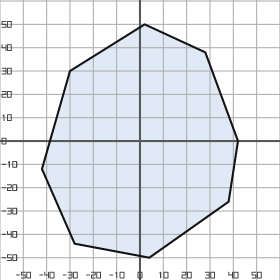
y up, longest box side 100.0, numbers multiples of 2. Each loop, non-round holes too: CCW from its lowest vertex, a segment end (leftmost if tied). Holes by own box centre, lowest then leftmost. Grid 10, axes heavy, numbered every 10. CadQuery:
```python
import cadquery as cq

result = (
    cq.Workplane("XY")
    .moveTo(4.0, -50.0)
    .lineTo(38.0, -26.0)
    .lineTo(42.0, 0.0)
    .lineTo(28.0, 38.0)
    .lineTo(2.0, 50.0)
    .lineTo(-30.0, 30.0)
    .lineTo(-42.0, -12.0)
    .lineTo(-28.0, -44.0)
    .close()
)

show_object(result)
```